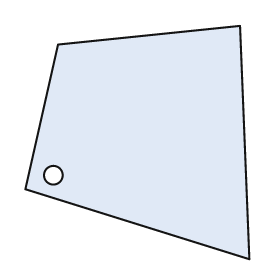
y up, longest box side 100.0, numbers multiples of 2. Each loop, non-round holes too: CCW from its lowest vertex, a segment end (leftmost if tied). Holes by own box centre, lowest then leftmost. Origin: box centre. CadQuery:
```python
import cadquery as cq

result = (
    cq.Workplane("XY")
    .moveTo(48.0, -50.0)
    .lineTo(44.0, 50.0)
    .lineTo(-34.0, 42.0)
    .lineTo(-48.0, -20.0)
    .close()
    .moveTo(-36.0, -14.0)
    .circle(4.0)
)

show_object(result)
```